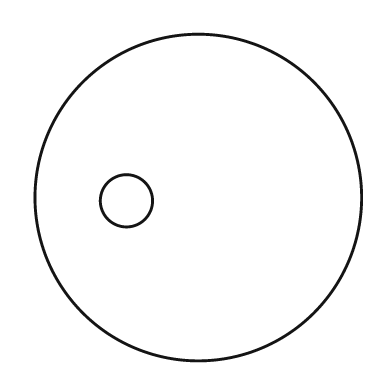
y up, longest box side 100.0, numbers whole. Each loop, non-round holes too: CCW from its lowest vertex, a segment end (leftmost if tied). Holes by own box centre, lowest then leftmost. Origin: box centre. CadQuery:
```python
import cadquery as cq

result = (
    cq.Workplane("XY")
    .moveTo(0.0, 0.0)
    .circle(50.0)
    .moveTo(-22.0, -1.0)
    .circle(8.0)
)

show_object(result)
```